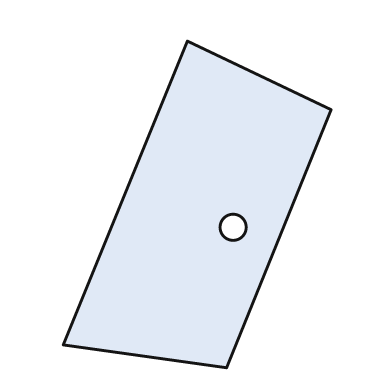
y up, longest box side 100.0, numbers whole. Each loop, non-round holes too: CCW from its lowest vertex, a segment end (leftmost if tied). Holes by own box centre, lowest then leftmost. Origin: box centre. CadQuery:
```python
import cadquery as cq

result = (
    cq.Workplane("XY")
    .moveTo(9.0, -50.0)
    .lineTo(41.0, 29.0)
    .lineTo(-3.0, 50.0)
    .lineTo(-41.0, -43.0)
    .close()
    .moveTo(11.0, -7.0)
    .circle(4.0)
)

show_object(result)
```